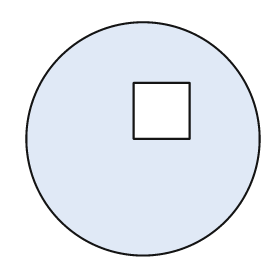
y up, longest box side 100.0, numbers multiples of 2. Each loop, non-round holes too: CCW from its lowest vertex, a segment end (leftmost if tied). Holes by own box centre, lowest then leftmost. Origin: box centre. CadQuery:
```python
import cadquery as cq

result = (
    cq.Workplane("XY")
    .moveTo(0.0, 0.0)
    .circle(50.0)
    .moveTo(-4.0, 0.0)
    .lineTo(20.0, 0.0)
    .lineTo(20.0, 24.0)
    .lineTo(-4.0, 24.0)
    .close()
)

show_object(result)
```